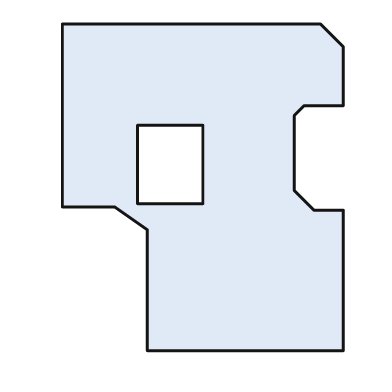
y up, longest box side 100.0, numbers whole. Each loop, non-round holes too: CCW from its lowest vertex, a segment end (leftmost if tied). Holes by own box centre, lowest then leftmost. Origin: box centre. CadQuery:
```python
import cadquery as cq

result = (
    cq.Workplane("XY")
    .moveTo(-17.0, -50.0)
    .lineTo(43.0, -50.0)
    .lineTo(43.0, -7.0)
    .lineTo(34.0, -7.0)
    .lineTo(28.0, -1.0)
    .lineTo(28.0, 22.0)
    .lineTo(31.0, 25.0)
    .lineTo(43.0, 25.0)
    .lineTo(43.0, 43.0)
    .lineTo(36.0, 50.0)
    .lineTo(-43.0, 50.0)
    .lineTo(-43.0, -6.0)
    .lineTo(-27.0, -6.0)
    .lineTo(-17.0, -13.0)
    .close()
    .moveTo(-20.0, -5.0)
    .lineTo(0.0, -5.0)
    .lineTo(0.0, 19.0)
    .lineTo(-20.0, 19.0)
    .close()
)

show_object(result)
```